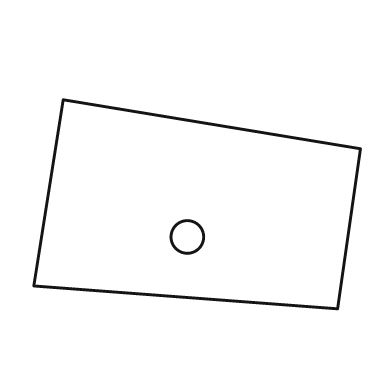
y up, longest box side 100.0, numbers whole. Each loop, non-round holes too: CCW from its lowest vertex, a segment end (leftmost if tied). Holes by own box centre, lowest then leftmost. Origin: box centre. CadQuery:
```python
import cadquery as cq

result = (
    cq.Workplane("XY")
    .moveTo(43.0, -32.0)
    .lineTo(50.0, 17.0)
    .lineTo(-41.0, 32.0)
    .lineTo(-50.0, -25.0)
    .close()
    .moveTo(-3.0, -10.0)
    .circle(5.0)
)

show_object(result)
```